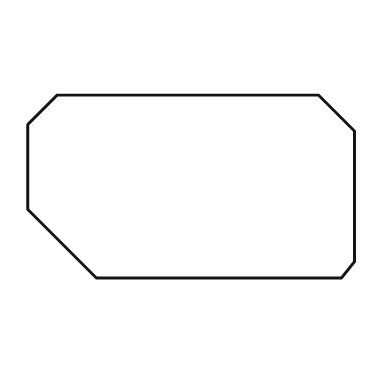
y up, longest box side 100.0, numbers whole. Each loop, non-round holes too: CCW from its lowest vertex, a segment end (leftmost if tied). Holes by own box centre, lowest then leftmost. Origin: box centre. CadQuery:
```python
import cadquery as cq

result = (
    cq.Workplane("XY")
    .moveTo(-29.0, -28.0)
    .lineTo(46.0, -28.0)
    .lineTo(50.0, -23.0)
    .lineTo(50.0, 17.0)
    .lineTo(39.0, 28.0)
    .lineTo(-41.0, 28.0)
    .lineTo(-50.0, 19.0)
    .lineTo(-50.0, -7.0)
    .close()
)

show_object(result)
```